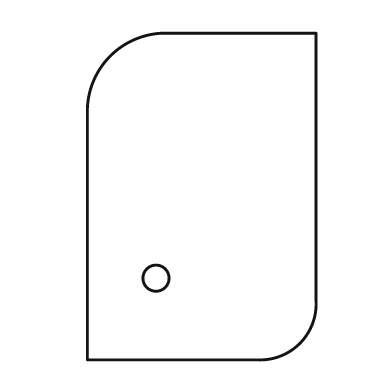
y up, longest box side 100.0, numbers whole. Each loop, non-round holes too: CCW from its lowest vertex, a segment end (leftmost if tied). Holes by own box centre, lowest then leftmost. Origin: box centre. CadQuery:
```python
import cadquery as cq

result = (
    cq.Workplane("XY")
    .moveTo(-35.0, -50.0)
    .lineTo(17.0, -50.0)
    .threePointArc((30.0, -45.0), (35.0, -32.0))
    .lineTo(35.0, 50.0)
    .lineTo(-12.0, 50.0)
    .threePointArc((-28.0, 43.0), (-35.0, 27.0))
    .close()
    .moveTo(-14.0, -25.0)
    .circle(4.0)
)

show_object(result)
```